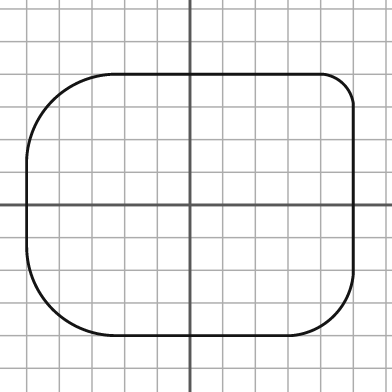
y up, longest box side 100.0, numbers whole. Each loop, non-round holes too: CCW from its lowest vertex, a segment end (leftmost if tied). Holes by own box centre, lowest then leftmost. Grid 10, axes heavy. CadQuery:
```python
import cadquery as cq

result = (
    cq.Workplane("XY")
    .moveTo(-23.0, -40.0)
    .lineTo(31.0, -40.0)
    .threePointArc((44.0, -34.0), (50.0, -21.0))
    .lineTo(50.0, 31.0)
    .threePointArc((47.0, 37.0), (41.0, 40.0))
    .lineTo(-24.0, 40.0)
    .threePointArc((-42.0, 32.0), (-50.0, 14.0))
    .lineTo(-50.0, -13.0)
    .threePointArc((-42.0, -32.0), (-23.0, -40.0))
    .close()
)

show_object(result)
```